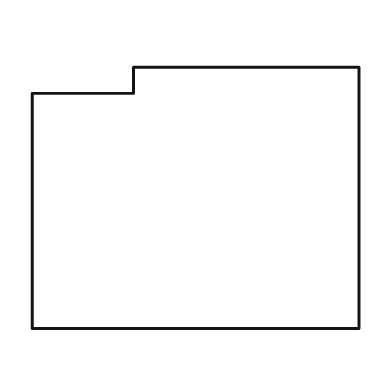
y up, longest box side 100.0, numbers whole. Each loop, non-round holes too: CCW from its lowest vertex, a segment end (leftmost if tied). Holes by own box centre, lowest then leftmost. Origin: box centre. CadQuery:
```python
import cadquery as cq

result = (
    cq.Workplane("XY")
    .moveTo(-50.0, -40.0)
    .lineTo(50.0, -40.0)
    .lineTo(50.0, 40.0)
    .lineTo(-19.0, 40.0)
    .lineTo(-19.0, 32.0)
    .lineTo(-50.0, 32.0)
    .close()
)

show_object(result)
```